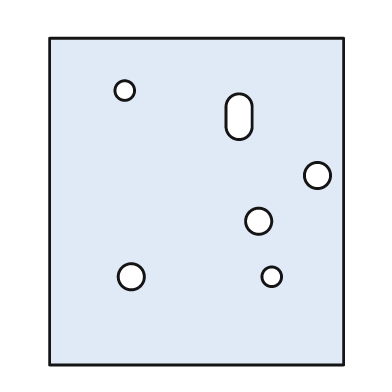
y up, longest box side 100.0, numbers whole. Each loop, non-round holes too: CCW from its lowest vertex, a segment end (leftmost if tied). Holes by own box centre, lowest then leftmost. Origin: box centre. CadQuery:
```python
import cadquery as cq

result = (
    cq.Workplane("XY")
    .moveTo(-45.0, -50.0)
    .lineTo(45.0, -50.0)
    .lineTo(45.0, 50.0)
    .lineTo(-45.0, 50.0)
    .close()
    .moveTo(-20.0, -23.0)
    .circle(4.0)
    .moveTo(23.0, -23.0)
    .circle(3.0)
    .moveTo(19.0, -6.0)
    .circle(4.0)
    .moveTo(37.0, 8.0)
    .circle(4.0)
    .moveTo(9.0, 23.0)
    .threePointArc((13.0, 19.0), (17.0, 23.0))
    .lineTo(17.0, 29.0)
    .threePointArc((13.0, 33.0), (9.0, 29.0))
    .close()
    .moveTo(-22.0, 34.0)
    .circle(3.0)
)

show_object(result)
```